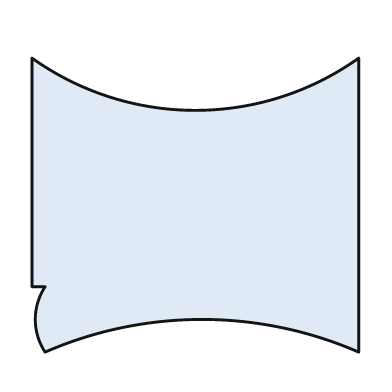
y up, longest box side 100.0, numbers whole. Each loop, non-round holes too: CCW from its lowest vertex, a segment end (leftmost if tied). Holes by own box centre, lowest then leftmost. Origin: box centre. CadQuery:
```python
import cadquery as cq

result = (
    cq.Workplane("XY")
    .moveTo(-46.0, -45.0)
    .threePointArc((2.0, -35.0), (50.0, -45.0))
    .lineTo(50.0, 45.0)
    .threePointArc((0.0, 29.0), (-50.0, 45.0))
    .lineTo(-50.0, -25.0)
    .lineTo(-46.0, -25.0)
    .threePointArc((-49.0, -35.0), (-46.0, -45.0))
    .close()
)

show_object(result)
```